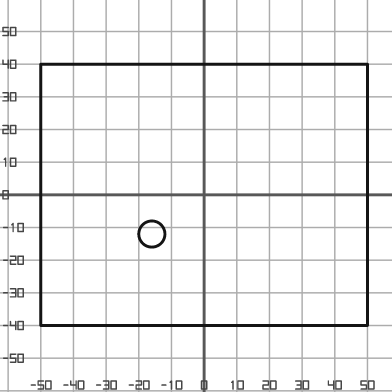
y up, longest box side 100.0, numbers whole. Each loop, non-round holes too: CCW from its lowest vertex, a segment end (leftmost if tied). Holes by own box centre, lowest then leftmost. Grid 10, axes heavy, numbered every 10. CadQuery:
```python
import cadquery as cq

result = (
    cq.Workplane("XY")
    .moveTo(-50.0, -40.0)
    .lineTo(50.0, -40.0)
    .lineTo(50.0, 40.0)
    .lineTo(-50.0, 40.0)
    .close()
    .moveTo(-16.0, -12.0)
    .circle(4.0)
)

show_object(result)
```